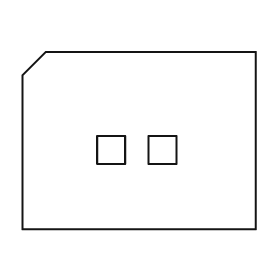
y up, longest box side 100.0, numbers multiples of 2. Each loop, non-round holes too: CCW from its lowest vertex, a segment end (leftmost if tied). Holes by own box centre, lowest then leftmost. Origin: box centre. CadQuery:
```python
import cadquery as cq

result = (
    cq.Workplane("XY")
    .moveTo(-50.0, -38.0)
    .lineTo(50.0, -38.0)
    .lineTo(50.0, 38.0)
    .lineTo(-40.0, 38.0)
    .lineTo(-50.0, 28.0)
    .close()
    .moveTo(-18.0, -10.0)
    .lineTo(-6.0, -10.0)
    .lineTo(-6.0, 2.0)
    .lineTo(-18.0, 2.0)
    .close()
    .moveTo(4.0, -10.0)
    .lineTo(16.0, -10.0)
    .lineTo(16.0, 2.0)
    .lineTo(4.0, 2.0)
    .close()
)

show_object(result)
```